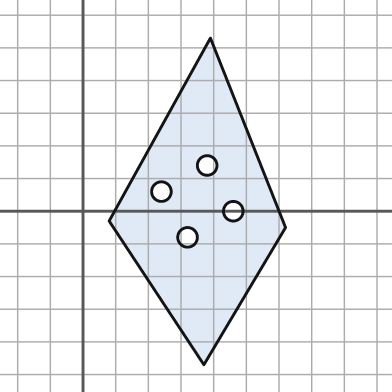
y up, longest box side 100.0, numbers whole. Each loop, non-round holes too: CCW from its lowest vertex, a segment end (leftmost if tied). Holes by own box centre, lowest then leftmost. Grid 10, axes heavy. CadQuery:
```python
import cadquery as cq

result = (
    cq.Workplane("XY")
    .moveTo(37.0, -47.0)
    .lineTo(62.0, -5.0)
    .lineTo(39.0, 53.0)
    .lineTo(8.0, -3.0)
    .close()
    .moveTo(32.0, -8.0)
    .circle(3.0)
    .moveTo(46.0, 0.0)
    .circle(3.0)
    .moveTo(24.0, 6.0)
    .circle(3.0)
    .moveTo(38.0, 14.0)
    .circle(3.0)
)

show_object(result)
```